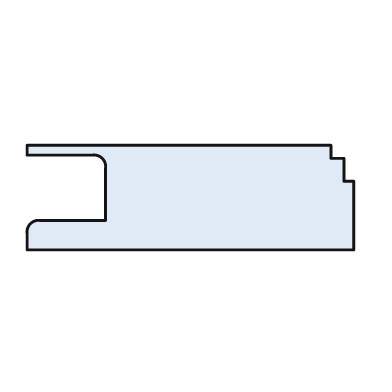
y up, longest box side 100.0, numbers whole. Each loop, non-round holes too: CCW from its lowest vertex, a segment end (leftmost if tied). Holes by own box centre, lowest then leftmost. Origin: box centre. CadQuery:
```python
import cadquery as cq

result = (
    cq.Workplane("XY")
    .moveTo(-50.0, -16.0)
    .lineTo(50.0, -16.0)
    .lineTo(50.0, 5.0)
    .lineTo(47.0, 5.0)
    .lineTo(47.0, 12.0)
    .lineTo(43.0, 12.0)
    .lineTo(43.0, 16.0)
    .lineTo(-50.0, 16.0)
    .lineTo(-50.0, 13.0)
    .lineTo(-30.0, 13.0)
    .threePointArc((-27.0, 12.0), (-26.0, 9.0))
    .lineTo(-26.0, -7.0)
    .lineTo(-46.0, -7.0)
    .threePointArc((-49.0, -8.0), (-50.0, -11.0))
    .close()
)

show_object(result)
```